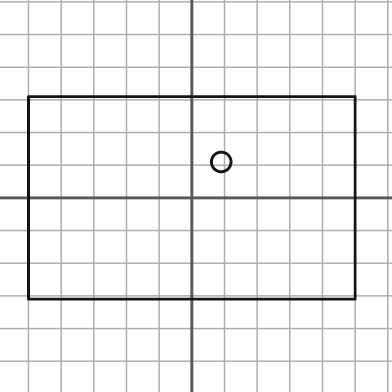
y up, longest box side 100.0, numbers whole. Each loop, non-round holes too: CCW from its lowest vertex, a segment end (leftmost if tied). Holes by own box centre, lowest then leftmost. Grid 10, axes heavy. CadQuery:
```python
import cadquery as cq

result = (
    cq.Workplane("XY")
    .moveTo(-50.0, -31.0)
    .lineTo(50.0, -31.0)
    .lineTo(50.0, 31.0)
    .lineTo(-50.0, 31.0)
    .close()
    .moveTo(9.0, 11.0)
    .circle(3.0)
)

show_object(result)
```